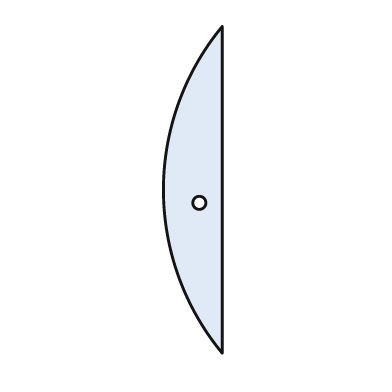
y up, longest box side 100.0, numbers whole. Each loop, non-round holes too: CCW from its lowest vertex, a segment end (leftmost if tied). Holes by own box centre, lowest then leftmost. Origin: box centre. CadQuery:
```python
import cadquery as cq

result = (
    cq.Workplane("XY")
    .moveTo(9.0, -50.0)
    .lineTo(9.0, 50.0)
    .threePointArc((-9.0, 0.0), (9.0, -50.0))
    .close()
    .moveTo(2.0, -4.0)
    .circle(2.0)
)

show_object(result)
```